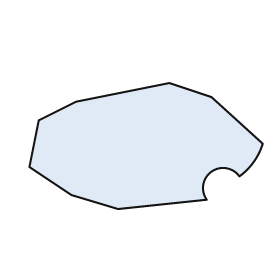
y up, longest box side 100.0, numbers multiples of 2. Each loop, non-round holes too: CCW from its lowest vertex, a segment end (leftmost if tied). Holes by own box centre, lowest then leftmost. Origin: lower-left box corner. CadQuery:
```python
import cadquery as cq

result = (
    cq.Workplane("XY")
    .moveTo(38.0, 0.0)
    .lineTo(76.0, 4.0)
    .threePointArc((78.0, 16.0), (90.0, 14.0))
    .threePointArc((96.0, 20.0), (100.0, 28.0))
    .lineTo(78.0, 48.0)
    .lineTo(60.0, 54.0)
    .lineTo(20.0, 46.0)
    .lineTo(4.0, 38.0)
    .lineTo(0.0, 18.0)
    .lineTo(18.0, 6.0)
    .close()
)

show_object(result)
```